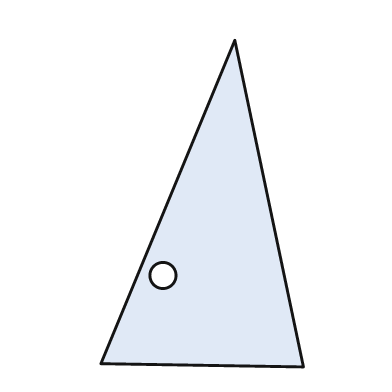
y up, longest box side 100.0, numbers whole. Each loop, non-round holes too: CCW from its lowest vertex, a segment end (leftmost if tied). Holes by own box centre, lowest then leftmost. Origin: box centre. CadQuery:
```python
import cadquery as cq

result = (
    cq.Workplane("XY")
    .moveTo(31.0, -50.0)
    .lineTo(10.0, 50.0)
    .lineTo(-31.0, -49.0)
    .close()
    .moveTo(-12.0, -22.0)
    .circle(4.0)
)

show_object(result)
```